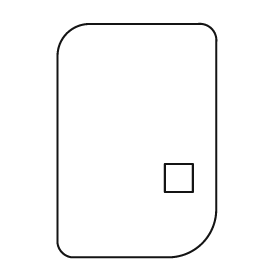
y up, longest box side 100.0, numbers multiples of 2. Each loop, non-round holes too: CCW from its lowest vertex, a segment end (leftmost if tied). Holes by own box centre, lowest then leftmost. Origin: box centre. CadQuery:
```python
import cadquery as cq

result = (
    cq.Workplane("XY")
    .moveTo(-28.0, -50.0)
    .lineTo(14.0, -50.0)
    .threePointArc((28.0, -44.0), (34.0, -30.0))
    .lineTo(34.0, 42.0)
    .threePointArc((32.0, 48.0), (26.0, 50.0))
    .lineTo(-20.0, 50.0)
    .threePointArc((-30.0, 46.0), (-34.0, 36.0))
    .lineTo(-34.0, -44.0)
    .threePointArc((-32.0, -48.0), (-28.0, -50.0))
    .close()
    .moveTo(12.0, -22.0)
    .lineTo(24.0, -22.0)
    .lineTo(24.0, -10.0)
    .lineTo(12.0, -10.0)
    .close()
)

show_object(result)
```